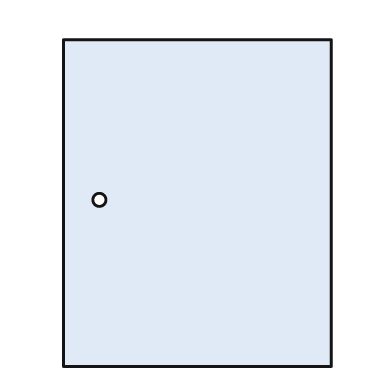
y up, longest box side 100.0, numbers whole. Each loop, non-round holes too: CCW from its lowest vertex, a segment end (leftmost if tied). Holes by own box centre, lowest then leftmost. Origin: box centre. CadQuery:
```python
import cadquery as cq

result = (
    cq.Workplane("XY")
    .moveTo(-41.0, -50.0)
    .lineTo(41.0, -50.0)
    .lineTo(41.0, 50.0)
    .lineTo(-41.0, 50.0)
    .close()
    .moveTo(-30.0, 1.0)
    .circle(2.0)
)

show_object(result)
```